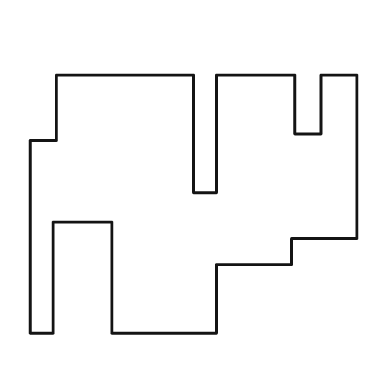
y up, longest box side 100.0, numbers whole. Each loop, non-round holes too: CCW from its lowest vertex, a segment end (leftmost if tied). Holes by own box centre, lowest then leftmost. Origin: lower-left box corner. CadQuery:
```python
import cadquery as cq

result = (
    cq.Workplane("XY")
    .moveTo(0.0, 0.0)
    .lineTo(7.0, 0.0)
    .lineTo(7.0, 34.0)
    .lineTo(25.0, 34.0)
    .lineTo(25.0, 0.0)
    .lineTo(57.0, 0.0)
    .lineTo(57.0, 21.0)
    .lineTo(80.0, 21.0)
    .lineTo(80.0, 29.0)
    .lineTo(100.0, 29.0)
    .lineTo(100.0, 79.0)
    .lineTo(89.0, 79.0)
    .lineTo(89.0, 61.0)
    .lineTo(81.0, 61.0)
    .lineTo(81.0, 79.0)
    .lineTo(57.0, 79.0)
    .lineTo(57.0, 43.0)
    .lineTo(50.0, 43.0)
    .lineTo(50.0, 79.0)
    .lineTo(8.0, 79.0)
    .lineTo(8.0, 59.0)
    .lineTo(0.0, 59.0)
    .close()
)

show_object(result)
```